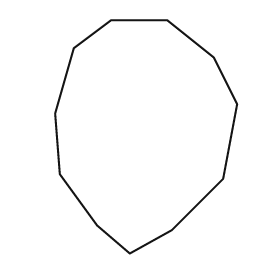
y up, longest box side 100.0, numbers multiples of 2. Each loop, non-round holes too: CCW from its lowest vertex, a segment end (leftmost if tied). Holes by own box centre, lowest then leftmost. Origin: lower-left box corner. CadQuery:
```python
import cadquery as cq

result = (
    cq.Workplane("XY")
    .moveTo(32.0, 0.0)
    .lineTo(50.0, 10.0)
    .lineTo(72.0, 32.0)
    .lineTo(78.0, 64.0)
    .lineTo(68.0, 84.0)
    .lineTo(48.0, 100.0)
    .lineTo(24.0, 100.0)
    .lineTo(8.0, 88.0)
    .lineTo(0.0, 60.0)
    .lineTo(2.0, 34.0)
    .lineTo(18.0, 12.0)
    .close()
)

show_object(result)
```